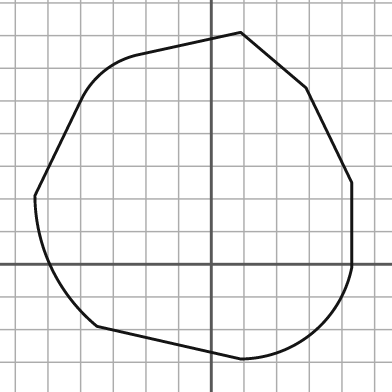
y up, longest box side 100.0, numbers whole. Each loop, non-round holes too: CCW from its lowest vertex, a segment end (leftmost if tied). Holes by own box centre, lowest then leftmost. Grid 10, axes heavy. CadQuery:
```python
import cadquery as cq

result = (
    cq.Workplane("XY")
    .moveTo(9.0, -29.0)
    .threePointArc((31.0, -21.0), (43.0, -1.0))
    .lineTo(43.0, 25.0)
    .lineTo(29.0, 54.0)
    .lineTo(9.0, 71.0)
    .lineTo(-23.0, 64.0)
    .threePointArc((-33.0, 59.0), (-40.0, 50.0))
    .lineTo(-54.0, 21.0)
    .threePointArc((-49.0, -1.0), (-35.0, -19.0))
    .close()
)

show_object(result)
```